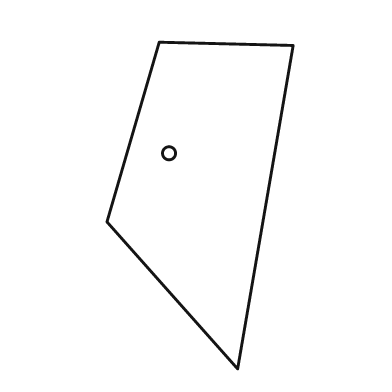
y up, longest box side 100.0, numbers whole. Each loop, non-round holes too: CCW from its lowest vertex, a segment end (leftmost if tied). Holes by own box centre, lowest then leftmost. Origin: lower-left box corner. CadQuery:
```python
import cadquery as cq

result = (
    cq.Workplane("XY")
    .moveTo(40.0, 0.0)
    .lineTo(57.0, 99.0)
    .lineTo(16.0, 100.0)
    .lineTo(0.0, 45.0)
    .close()
    .moveTo(19.0, 66.0)
    .circle(2.0)
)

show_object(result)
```